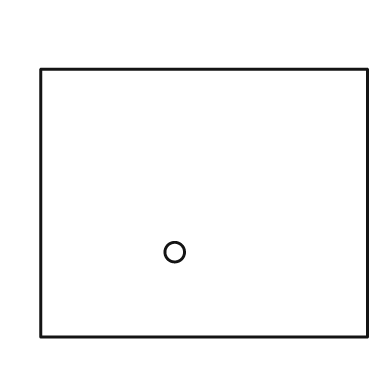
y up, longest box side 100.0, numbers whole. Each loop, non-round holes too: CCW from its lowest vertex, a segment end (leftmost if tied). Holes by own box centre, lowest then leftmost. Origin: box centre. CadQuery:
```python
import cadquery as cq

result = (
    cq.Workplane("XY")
    .moveTo(-50.0, -41.0)
    .lineTo(50.0, -41.0)
    .lineTo(50.0, 41.0)
    .lineTo(-50.0, 41.0)
    .close()
    .moveTo(-9.0, -15.0)
    .circle(3.0)
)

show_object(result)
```